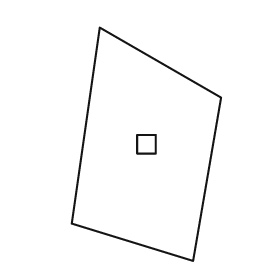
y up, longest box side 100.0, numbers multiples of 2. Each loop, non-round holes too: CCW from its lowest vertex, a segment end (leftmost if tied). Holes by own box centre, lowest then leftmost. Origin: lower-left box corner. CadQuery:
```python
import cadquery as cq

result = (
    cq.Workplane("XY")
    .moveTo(52.0, 0.0)
    .lineTo(64.0, 70.0)
    .lineTo(12.0, 100.0)
    .lineTo(0.0, 16.0)
    .close()
    .moveTo(28.0, 46.0)
    .lineTo(36.0, 46.0)
    .lineTo(36.0, 54.0)
    .lineTo(28.0, 54.0)
    .close()
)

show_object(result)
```